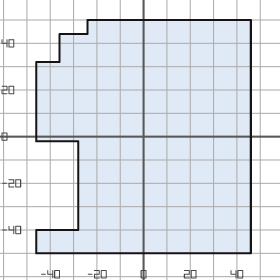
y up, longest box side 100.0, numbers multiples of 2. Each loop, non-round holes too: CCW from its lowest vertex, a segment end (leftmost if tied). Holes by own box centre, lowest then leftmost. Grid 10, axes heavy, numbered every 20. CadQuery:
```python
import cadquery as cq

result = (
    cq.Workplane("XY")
    .moveTo(-46.0, -50.0)
    .lineTo(46.0, -50.0)
    .lineTo(46.0, 50.0)
    .lineTo(-24.0, 50.0)
    .lineTo(-24.0, 44.0)
    .lineTo(-36.0, 44.0)
    .lineTo(-36.0, 32.0)
    .lineTo(-46.0, 32.0)
    .lineTo(-46.0, -2.0)
    .lineTo(-28.0, -2.0)
    .lineTo(-28.0, -40.0)
    .lineTo(-46.0, -40.0)
    .close()
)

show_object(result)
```